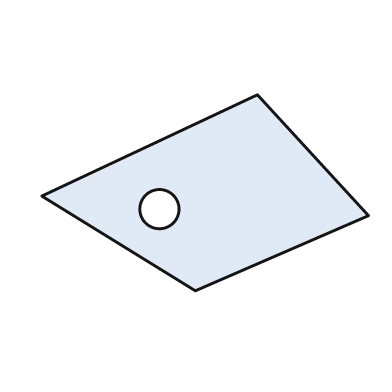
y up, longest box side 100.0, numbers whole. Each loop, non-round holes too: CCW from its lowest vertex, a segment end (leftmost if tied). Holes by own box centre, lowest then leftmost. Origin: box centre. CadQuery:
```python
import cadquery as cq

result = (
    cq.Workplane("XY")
    .moveTo(-3.0, -30.0)
    .lineTo(50.0, -7.0)
    .lineTo(16.0, 30.0)
    .lineTo(-50.0, -1.0)
    .close()
    .moveTo(-14.0, -5.0)
    .circle(6.0)
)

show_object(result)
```